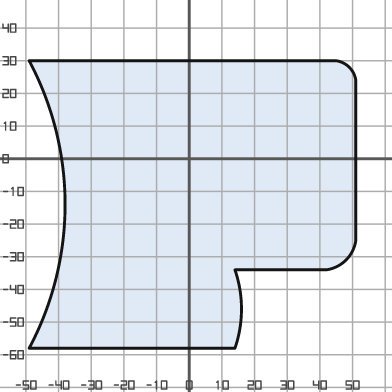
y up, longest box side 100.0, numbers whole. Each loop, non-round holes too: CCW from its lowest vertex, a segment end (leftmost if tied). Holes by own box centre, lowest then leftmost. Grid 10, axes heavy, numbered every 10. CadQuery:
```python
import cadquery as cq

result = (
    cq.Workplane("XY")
    .moveTo(-49.0, -58.0)
    .lineTo(14.0, -58.0)
    .threePointArc((16.0, -46.0), (14.0, -34.0))
    .lineTo(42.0, -34.0)
    .threePointArc((48.0, -31.0), (51.0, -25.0))
    .lineTo(51.0, 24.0)
    .threePointArc((49.0, 28.0), (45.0, 30.0))
    .lineTo(-49.0, 30.0)
    .threePointArc((-38.0, -14.0), (-49.0, -58.0))
    .close()
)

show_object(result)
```